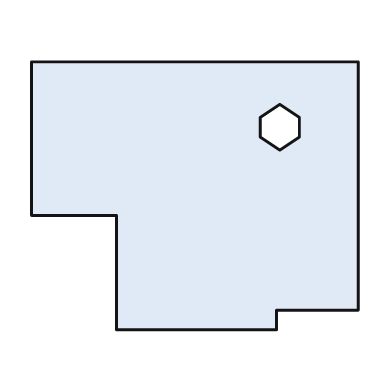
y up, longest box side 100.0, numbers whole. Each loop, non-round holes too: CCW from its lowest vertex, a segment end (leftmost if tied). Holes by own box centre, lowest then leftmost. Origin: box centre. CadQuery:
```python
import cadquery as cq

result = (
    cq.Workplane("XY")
    .moveTo(-24.0, -41.0)
    .lineTo(25.0, -41.0)
    .lineTo(25.0, -35.0)
    .lineTo(50.0, -35.0)
    .lineTo(50.0, 41.0)
    .lineTo(-50.0, 41.0)
    .lineTo(-50.0, -6.0)
    .lineTo(-24.0, -6.0)
    .close()
    .moveTo(26.0, 14.0)
    .lineTo(32.0, 18.0)
    .lineTo(32.0, 24.0)
    .lineTo(26.0, 28.0)
    .lineTo(20.0, 24.0)
    .lineTo(20.0, 18.0)
    .close()
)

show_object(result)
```